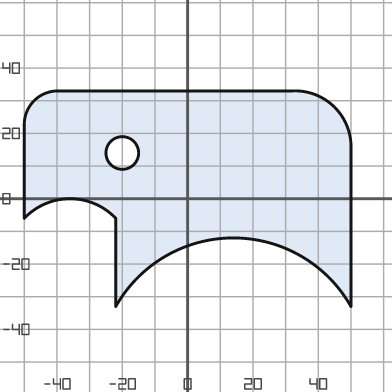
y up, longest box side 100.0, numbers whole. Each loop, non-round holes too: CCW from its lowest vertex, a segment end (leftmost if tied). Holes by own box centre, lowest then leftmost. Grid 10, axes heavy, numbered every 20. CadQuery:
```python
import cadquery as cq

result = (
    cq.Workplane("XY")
    .moveTo(-22.0, -33.0)
    .threePointArc((14.0, -12.0), (50.0, -33.0))
    .lineTo(50.0, 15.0)
    .threePointArc((45.0, 28.0), (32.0, 33.0))
    .lineTo(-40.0, 33.0)
    .threePointArc((-47.0, 30.0), (-50.0, 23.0))
    .lineTo(-50.0, -6.0)
    .threePointArc((-36.0, 0.0), (-22.0, -6.0))
    .close()
    .moveTo(-20.0, 14.0)
    .circle(5.0)
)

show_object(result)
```